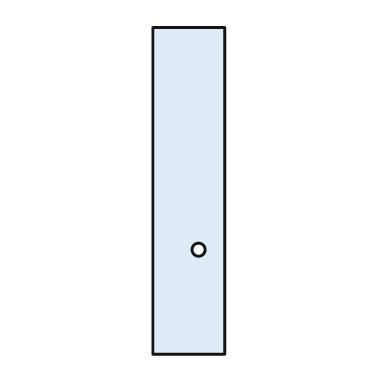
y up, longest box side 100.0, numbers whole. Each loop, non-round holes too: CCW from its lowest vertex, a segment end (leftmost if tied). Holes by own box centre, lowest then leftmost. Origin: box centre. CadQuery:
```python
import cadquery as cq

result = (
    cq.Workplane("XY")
    .moveTo(-11.0, -50.0)
    .lineTo(11.0, -50.0)
    .lineTo(11.0, 50.0)
    .lineTo(-11.0, 50.0)
    .close()
    .moveTo(3.0, -18.0)
    .circle(2.0)
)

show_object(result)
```